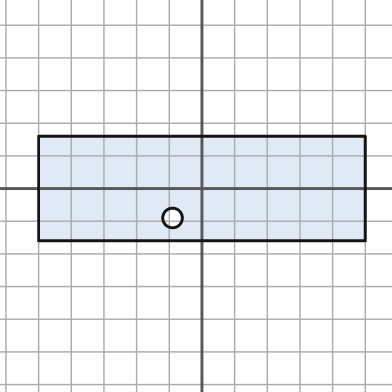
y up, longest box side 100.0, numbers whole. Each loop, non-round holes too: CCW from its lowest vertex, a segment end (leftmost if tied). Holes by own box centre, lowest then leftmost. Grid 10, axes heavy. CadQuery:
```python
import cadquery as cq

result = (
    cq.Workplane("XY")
    .moveTo(-50.0, -16.0)
    .lineTo(50.0, -16.0)
    .lineTo(50.0, 16.0)
    .lineTo(-50.0, 16.0)
    .close()
    .moveTo(-9.0, -9.0)
    .circle(3.0)
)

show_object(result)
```